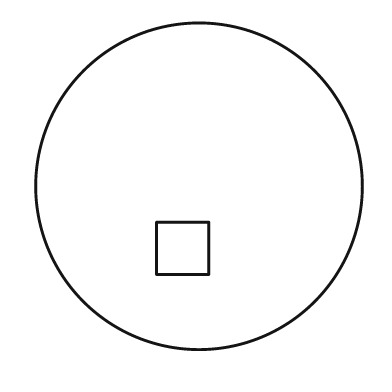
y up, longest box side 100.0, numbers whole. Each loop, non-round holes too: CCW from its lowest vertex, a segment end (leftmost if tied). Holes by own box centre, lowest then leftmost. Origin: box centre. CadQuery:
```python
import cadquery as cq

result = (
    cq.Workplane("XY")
    .moveTo(0.0, 0.0)
    .circle(50.0)
    .moveTo(-13.0, -27.0)
    .lineTo(3.0, -27.0)
    .lineTo(3.0, -11.0)
    .lineTo(-13.0, -11.0)
    .close()
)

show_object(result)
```